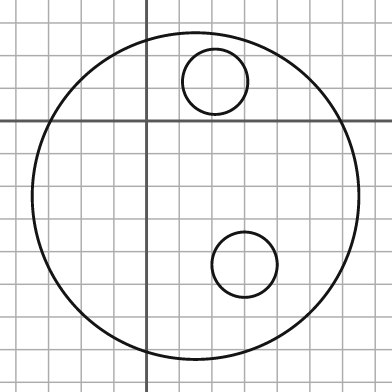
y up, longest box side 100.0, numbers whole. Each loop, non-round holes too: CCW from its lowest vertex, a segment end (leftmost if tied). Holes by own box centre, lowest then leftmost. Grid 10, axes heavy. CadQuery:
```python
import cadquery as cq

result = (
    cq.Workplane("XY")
    .moveTo(15.0, -23.0)
    .circle(50.0)
    .moveTo(30.0, -44.0)
    .circle(10.0)
    .moveTo(21.0, 12.0)
    .circle(10.0)
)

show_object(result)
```